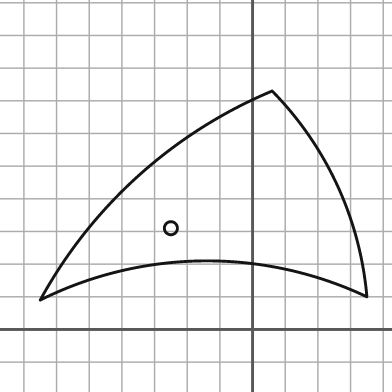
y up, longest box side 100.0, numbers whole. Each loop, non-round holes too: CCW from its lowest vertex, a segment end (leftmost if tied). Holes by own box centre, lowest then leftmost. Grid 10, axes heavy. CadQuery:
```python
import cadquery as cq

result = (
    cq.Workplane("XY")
    .moveTo(-65.0, 9.0)
    .threePointArc((-15.0, 21.0), (35.0, 10.0))
    .threePointArc((26.0, 44.0), (6.0, 73.0))
    .threePointArc((-35.0, 47.0), (-65.0, 9.0))
    .close()
    .moveTo(-25.0, 31.0)
    .circle(2.0)
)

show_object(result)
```